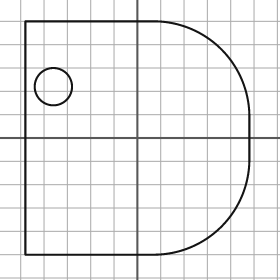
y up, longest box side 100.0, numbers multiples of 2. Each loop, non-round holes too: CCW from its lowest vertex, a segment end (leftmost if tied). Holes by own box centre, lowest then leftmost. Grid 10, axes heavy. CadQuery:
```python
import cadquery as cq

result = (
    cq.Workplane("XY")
    .moveTo(-48.0, -50.0)
    .lineTo(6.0, -50.0)
    .threePointArc((36.0, -38.0), (48.0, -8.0))
    .lineTo(48.0, 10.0)
    .threePointArc((36.0, 38.0), (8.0, 50.0))
    .lineTo(-48.0, 50.0)
    .close()
    .moveTo(-36.0, 22.0)
    .circle(8.0)
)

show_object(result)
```